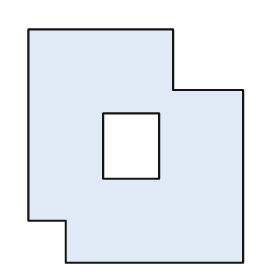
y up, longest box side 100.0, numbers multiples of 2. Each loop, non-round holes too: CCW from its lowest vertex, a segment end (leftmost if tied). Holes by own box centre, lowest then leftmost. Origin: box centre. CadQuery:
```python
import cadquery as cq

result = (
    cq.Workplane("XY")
    .moveTo(-30.0, -50.0)
    .lineTo(46.0, -50.0)
    .lineTo(46.0, 24.0)
    .lineTo(16.0, 24.0)
    .lineTo(16.0, 50.0)
    .lineTo(-46.0, 50.0)
    .lineTo(-46.0, -32.0)
    .lineTo(-30.0, -32.0)
    .close()
    .moveTo(-14.0, -14.0)
    .lineTo(10.0, -14.0)
    .lineTo(10.0, 14.0)
    .lineTo(-14.0, 14.0)
    .close()
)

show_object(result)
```